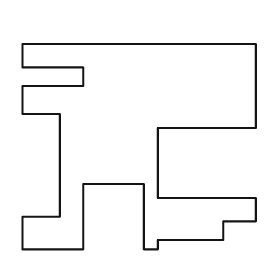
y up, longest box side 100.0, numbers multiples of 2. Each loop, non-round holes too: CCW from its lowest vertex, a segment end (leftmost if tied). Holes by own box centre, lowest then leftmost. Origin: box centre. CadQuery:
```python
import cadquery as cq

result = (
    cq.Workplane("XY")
    .moveTo(-50.0, -44.0)
    .lineTo(-24.0, -44.0)
    .lineTo(-24.0, -16.0)
    .lineTo(2.0, -16.0)
    .lineTo(2.0, -44.0)
    .lineTo(8.0, -44.0)
    .lineTo(8.0, -40.0)
    .lineTo(36.0, -40.0)
    .lineTo(36.0, -32.0)
    .lineTo(50.0, -32.0)
    .lineTo(50.0, -22.0)
    .lineTo(8.0, -22.0)
    .lineTo(8.0, 8.0)
    .lineTo(50.0, 8.0)
    .lineTo(50.0, 44.0)
    .lineTo(-50.0, 44.0)
    .lineTo(-50.0, 34.0)
    .lineTo(-24.0, 34.0)
    .lineTo(-24.0, 26.0)
    .lineTo(-50.0, 26.0)
    .lineTo(-50.0, 14.0)
    .lineTo(-34.0, 14.0)
    .lineTo(-34.0, -30.0)
    .lineTo(-50.0, -30.0)
    .close()
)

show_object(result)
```